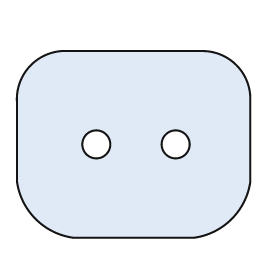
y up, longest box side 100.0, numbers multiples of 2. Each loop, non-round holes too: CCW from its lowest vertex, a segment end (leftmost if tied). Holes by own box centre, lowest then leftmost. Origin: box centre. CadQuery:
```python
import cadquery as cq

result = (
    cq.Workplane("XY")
    .moveTo(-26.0, -40.0)
    .lineTo(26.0, -40.0)
    .threePointArc((42.0, -32.0), (50.0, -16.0))
    .lineTo(50.0, 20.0)
    .threePointArc((44.0, 34.0), (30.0, 40.0))
    .lineTo(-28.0, 40.0)
    .threePointArc((-44.0, 34.0), (-50.0, 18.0))
    .lineTo(-50.0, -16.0)
    .threePointArc((-42.0, -32.0), (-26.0, -40.0))
    .close()
    .moveTo(-16.0, 0.0)
    .circle(6.0)
    .moveTo(18.0, 0.0)
    .circle(6.0)
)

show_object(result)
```